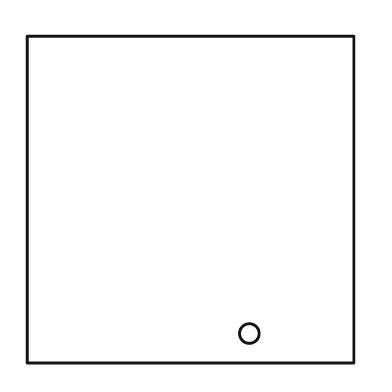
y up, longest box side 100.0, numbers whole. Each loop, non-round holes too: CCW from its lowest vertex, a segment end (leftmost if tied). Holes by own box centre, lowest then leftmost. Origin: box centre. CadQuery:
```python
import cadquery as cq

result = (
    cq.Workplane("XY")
    .moveTo(-50.0, -50.0)
    .lineTo(50.0, -50.0)
    .lineTo(50.0, 50.0)
    .lineTo(-50.0, 50.0)
    .close()
    .moveTo(18.0, -41.0)
    .circle(3.0)
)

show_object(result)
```